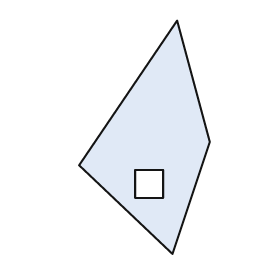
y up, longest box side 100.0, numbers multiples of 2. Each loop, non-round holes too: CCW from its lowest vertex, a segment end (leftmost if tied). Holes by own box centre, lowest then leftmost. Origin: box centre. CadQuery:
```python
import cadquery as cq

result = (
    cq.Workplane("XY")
    .moveTo(12.0, -50.0)
    .lineTo(28.0, -2.0)
    .lineTo(14.0, 50.0)
    .lineTo(-28.0, -12.0)
    .close()
    .moveTo(-4.0, -26.0)
    .lineTo(8.0, -26.0)
    .lineTo(8.0, -14.0)
    .lineTo(-4.0, -14.0)
    .close()
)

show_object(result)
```